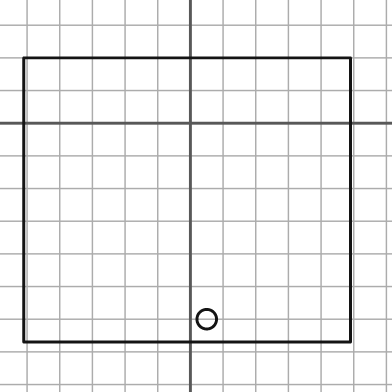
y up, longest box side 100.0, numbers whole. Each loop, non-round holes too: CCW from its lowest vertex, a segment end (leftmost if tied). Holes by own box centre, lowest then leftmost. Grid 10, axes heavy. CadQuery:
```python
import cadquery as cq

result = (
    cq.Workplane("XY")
    .moveTo(-51.0, -67.0)
    .lineTo(49.0, -67.0)
    .lineTo(49.0, 20.0)
    .lineTo(-51.0, 20.0)
    .close()
    .moveTo(5.0, -60.0)
    .circle(3.0)
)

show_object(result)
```